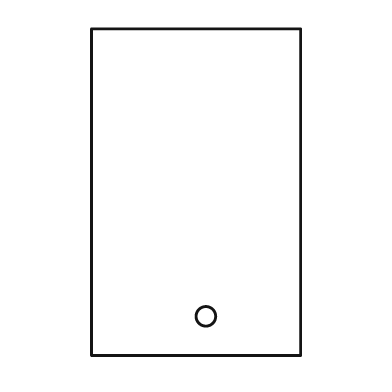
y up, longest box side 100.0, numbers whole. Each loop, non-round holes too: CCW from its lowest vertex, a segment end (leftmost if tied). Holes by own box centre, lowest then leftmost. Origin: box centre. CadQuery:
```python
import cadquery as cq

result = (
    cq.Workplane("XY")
    .moveTo(-32.0, -50.0)
    .lineTo(32.0, -50.0)
    .lineTo(32.0, 50.0)
    .lineTo(-32.0, 50.0)
    .close()
    .moveTo(3.0, -38.0)
    .circle(3.0)
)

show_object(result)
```